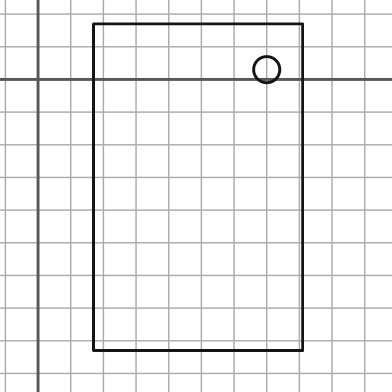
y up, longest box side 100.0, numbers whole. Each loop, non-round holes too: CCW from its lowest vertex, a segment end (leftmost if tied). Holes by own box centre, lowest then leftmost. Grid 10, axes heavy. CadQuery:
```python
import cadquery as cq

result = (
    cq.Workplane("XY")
    .moveTo(17.0, -83.0)
    .lineTo(81.0, -83.0)
    .lineTo(81.0, 17.0)
    .lineTo(17.0, 17.0)
    .close()
    .moveTo(70.0, 3.0)
    .circle(4.0)
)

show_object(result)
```